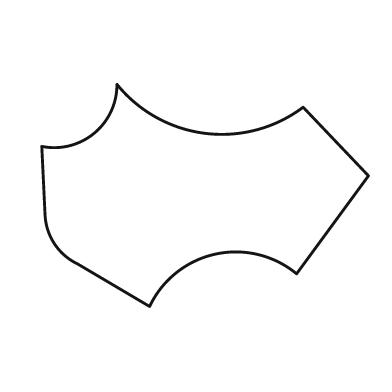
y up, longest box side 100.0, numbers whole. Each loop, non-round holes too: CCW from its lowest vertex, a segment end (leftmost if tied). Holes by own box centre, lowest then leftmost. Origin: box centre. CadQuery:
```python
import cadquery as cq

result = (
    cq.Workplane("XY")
    .moveTo(-17.0, -34.0)
    .threePointArc((3.0, -18.0), (28.0, -24.0))
    .lineTo(50.0, 6.0)
    .lineTo(30.0, 27.0)
    .threePointArc((0.0, 19.0), (-27.0, 34.0))
    .threePointArc((-34.0, 19.0), (-50.0, 15.0))
    .lineTo(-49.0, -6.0)
    .threePointArc((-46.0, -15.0), (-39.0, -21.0))
    .close()
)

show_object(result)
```